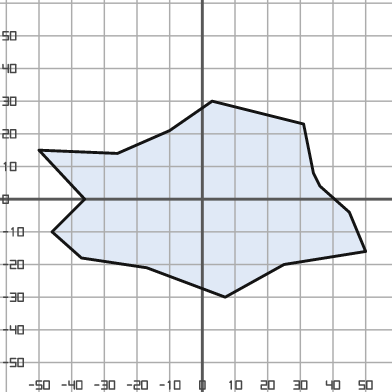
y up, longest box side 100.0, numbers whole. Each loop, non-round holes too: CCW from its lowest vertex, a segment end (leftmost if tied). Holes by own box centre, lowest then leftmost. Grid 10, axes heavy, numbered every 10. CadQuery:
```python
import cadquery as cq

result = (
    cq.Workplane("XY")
    .moveTo(7.0, -30.0)
    .lineTo(25.0, -20.0)
    .lineTo(50.0, -16.0)
    .lineTo(45.0, -4.0)
    .lineTo(36.0, 4.0)
    .lineTo(34.0, 8.0)
    .lineTo(31.0, 23.0)
    .lineTo(3.0, 30.0)
    .lineTo(-10.0, 21.0)
    .lineTo(-26.0, 14.0)
    .lineTo(-50.0, 15.0)
    .lineTo(-36.0, 0.0)
    .lineTo(-46.0, -10.0)
    .lineTo(-37.0, -18.0)
    .lineTo(-17.0, -21.0)
    .close()
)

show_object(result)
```